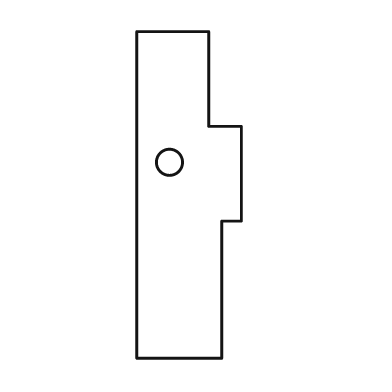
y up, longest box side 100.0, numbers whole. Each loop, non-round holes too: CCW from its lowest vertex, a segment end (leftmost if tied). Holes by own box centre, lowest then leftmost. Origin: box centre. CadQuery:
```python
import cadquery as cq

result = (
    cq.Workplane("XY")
    .moveTo(-16.0, -50.0)
    .lineTo(10.0, -50.0)
    .lineTo(10.0, -8.0)
    .lineTo(16.0, -8.0)
    .lineTo(16.0, 21.0)
    .lineTo(6.0, 21.0)
    .lineTo(6.0, 50.0)
    .lineTo(-16.0, 50.0)
    .close()
    .moveTo(-6.0, 10.0)
    .circle(4.0)
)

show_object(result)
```